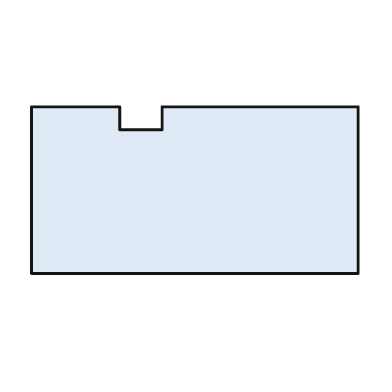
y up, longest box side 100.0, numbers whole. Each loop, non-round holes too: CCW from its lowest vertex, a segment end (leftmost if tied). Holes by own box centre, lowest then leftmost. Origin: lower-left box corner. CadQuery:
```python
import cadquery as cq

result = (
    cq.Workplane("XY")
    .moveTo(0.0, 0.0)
    .lineTo(100.0, 0.0)
    .lineTo(100.0, 51.0)
    .lineTo(40.0, 51.0)
    .lineTo(40.0, 44.0)
    .lineTo(27.0, 44.0)
    .lineTo(27.0, 51.0)
    .lineTo(0.0, 51.0)
    .close()
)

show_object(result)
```